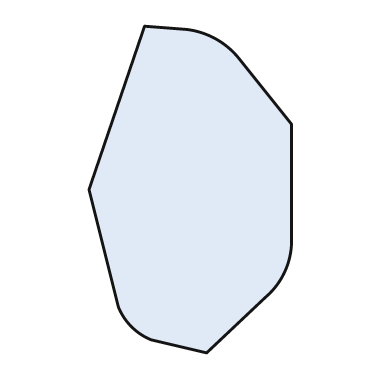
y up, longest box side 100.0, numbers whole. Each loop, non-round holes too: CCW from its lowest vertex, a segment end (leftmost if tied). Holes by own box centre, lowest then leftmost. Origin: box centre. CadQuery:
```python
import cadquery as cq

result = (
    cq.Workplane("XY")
    .moveTo(5.0, -50.0)
    .lineTo(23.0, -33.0)
    .threePointArc((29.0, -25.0), (31.0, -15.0))
    .lineTo(31.0, 20.0)
    .lineTo(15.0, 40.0)
    .threePointArc((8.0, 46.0), (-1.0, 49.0))
    .lineTo(-14.0, 50.0)
    .lineTo(-31.0, 0.0)
    .lineTo(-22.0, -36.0)
    .threePointArc((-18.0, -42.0), (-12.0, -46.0))
    .close()
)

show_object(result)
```